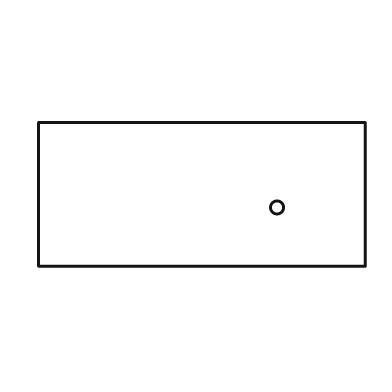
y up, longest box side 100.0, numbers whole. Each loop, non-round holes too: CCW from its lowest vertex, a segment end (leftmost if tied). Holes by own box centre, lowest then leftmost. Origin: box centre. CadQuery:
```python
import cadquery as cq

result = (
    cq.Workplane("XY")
    .moveTo(-50.0, -22.0)
    .lineTo(50.0, -22.0)
    .lineTo(50.0, 22.0)
    .lineTo(-50.0, 22.0)
    .close()
    .moveTo(23.0, -4.0)
    .circle(2.0)
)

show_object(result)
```